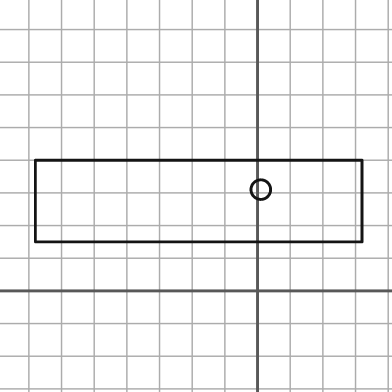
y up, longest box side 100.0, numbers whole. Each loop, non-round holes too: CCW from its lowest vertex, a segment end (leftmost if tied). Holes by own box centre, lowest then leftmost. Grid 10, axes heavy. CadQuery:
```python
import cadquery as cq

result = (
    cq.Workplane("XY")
    .moveTo(-68.0, 15.0)
    .lineTo(32.0, 15.0)
    .lineTo(32.0, 40.0)
    .lineTo(-68.0, 40.0)
    .close()
    .moveTo(1.0, 31.0)
    .circle(3.0)
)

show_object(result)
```